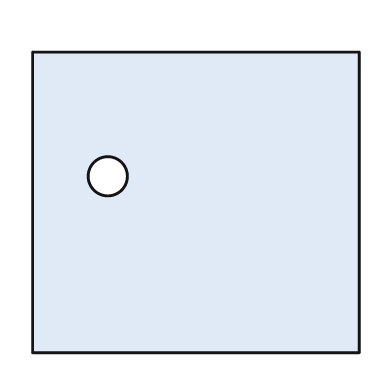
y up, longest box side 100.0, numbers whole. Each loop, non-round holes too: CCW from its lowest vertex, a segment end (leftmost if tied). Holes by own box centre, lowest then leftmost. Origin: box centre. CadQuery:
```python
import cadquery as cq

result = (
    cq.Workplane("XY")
    .moveTo(-50.0, -46.0)
    .lineTo(50.0, -46.0)
    .lineTo(50.0, 46.0)
    .lineTo(-50.0, 46.0)
    .close()
    .moveTo(-27.0, 8.0)
    .circle(6.0)
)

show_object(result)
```